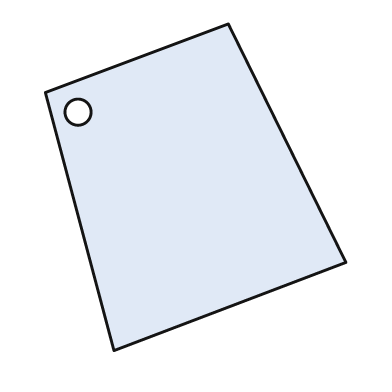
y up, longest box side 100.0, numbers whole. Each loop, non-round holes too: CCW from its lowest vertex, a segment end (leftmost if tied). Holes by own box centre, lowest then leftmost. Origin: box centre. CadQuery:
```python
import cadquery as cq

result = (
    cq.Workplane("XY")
    .moveTo(-25.0, -50.0)
    .lineTo(46.0, -23.0)
    .lineTo(10.0, 50.0)
    .lineTo(-46.0, 29.0)
    .close()
    .moveTo(-36.0, 23.0)
    .circle(4.0)
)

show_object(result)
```